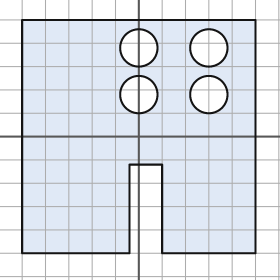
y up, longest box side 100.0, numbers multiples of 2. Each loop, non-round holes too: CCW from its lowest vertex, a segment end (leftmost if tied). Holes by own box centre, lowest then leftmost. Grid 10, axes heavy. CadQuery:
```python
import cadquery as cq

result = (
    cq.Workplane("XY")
    .moveTo(-50.0, -50.0)
    .lineTo(-4.0, -50.0)
    .lineTo(-4.0, -12.0)
    .lineTo(10.0, -12.0)
    .lineTo(10.0, -50.0)
    .lineTo(50.0, -50.0)
    .lineTo(50.0, 50.0)
    .lineTo(-50.0, 50.0)
    .close()
    .moveTo(0.0, 18.0)
    .circle(8.0)
    .moveTo(30.0, 18.0)
    .circle(8.0)
    .moveTo(0.0, 38.0)
    .circle(8.0)
    .moveTo(30.0, 38.0)
    .circle(8.0)
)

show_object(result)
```